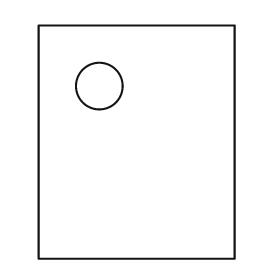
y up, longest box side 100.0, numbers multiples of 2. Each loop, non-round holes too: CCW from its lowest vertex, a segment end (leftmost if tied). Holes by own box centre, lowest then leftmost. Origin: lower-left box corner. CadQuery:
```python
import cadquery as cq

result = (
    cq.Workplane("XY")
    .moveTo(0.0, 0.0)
    .lineTo(84.0, 0.0)
    .lineTo(84.0, 100.0)
    .lineTo(0.0, 100.0)
    .close()
    .moveTo(26.0, 74.0)
    .circle(10.0)
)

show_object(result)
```